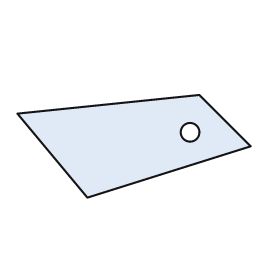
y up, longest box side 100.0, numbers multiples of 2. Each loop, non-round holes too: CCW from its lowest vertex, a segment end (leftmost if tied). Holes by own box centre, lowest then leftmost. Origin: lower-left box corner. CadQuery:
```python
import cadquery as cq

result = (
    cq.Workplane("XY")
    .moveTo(30.0, 0.0)
    .lineTo(100.0, 22.0)
    .lineTo(78.0, 44.0)
    .lineTo(0.0, 36.0)
    .close()
    .moveTo(74.0, 28.0)
    .circle(4.0)
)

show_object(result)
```